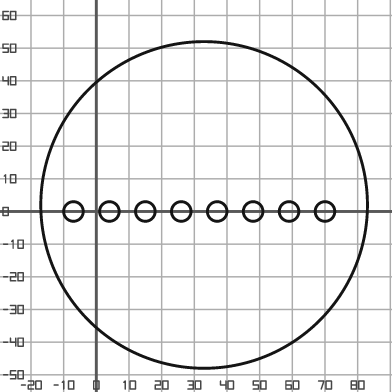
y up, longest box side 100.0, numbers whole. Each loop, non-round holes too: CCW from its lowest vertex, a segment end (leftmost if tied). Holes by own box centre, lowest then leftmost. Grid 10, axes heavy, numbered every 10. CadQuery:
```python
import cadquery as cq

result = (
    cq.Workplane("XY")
    .moveTo(33.0, 2.0)
    .circle(50.0)
    .moveTo(-7.0, 0.0)
    .circle(3.0)
    .moveTo(4.0, 0.0)
    .circle(3.0)
    .moveTo(15.0, 0.0)
    .circle(3.0)
    .moveTo(26.0, 0.0)
    .circle(3.0)
    .moveTo(37.0, 0.0)
    .circle(3.0)
    .moveTo(48.0, 0.0)
    .circle(3.0)
    .moveTo(59.0, 0.0)
    .circle(3.0)
    .moveTo(70.0, 0.0)
    .circle(3.0)
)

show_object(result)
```